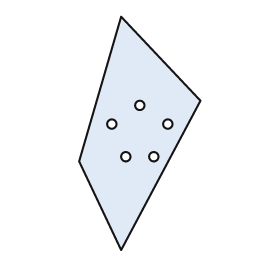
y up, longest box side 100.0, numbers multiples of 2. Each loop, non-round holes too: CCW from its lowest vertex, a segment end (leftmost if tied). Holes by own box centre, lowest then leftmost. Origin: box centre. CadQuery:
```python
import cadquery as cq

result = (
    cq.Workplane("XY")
    .moveTo(-8.0, -50.0)
    .lineTo(26.0, 14.0)
    .lineTo(-8.0, 50.0)
    .lineTo(-26.0, -12.0)
    .close()
    .moveTo(-6.0, -10.0)
    .circle(2.0)
    .moveTo(6.0, -10.0)
    .circle(2.0)
    .moveTo(-12.0, 4.0)
    .circle(2.0)
    .moveTo(12.0, 4.0)
    .circle(2.0)
    .moveTo(0.0, 12.0)
    .circle(2.0)
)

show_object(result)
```